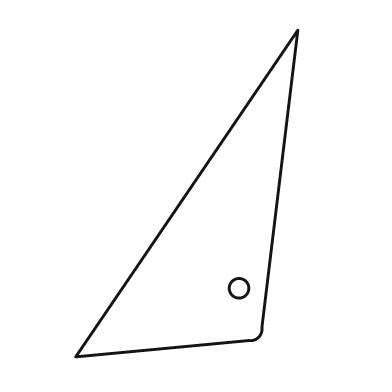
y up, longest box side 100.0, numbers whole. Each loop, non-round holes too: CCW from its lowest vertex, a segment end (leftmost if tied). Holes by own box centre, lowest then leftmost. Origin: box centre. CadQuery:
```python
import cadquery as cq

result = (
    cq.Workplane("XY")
    .moveTo(-34.0, -50.0)
    .lineTo(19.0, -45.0)
    .threePointArc((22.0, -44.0), (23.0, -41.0))
    .lineTo(34.0, 50.0)
    .close()
    .moveTo(16.0, -29.0)
    .circle(3.0)
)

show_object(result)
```